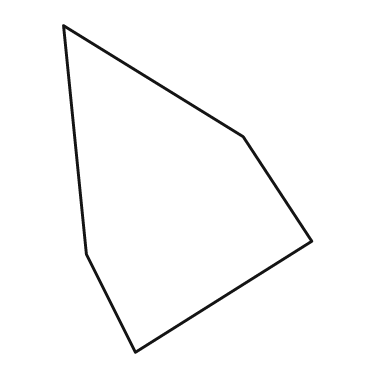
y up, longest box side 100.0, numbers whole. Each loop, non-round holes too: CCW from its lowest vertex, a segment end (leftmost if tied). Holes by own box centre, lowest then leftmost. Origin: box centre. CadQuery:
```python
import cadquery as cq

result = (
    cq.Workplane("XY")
    .moveTo(-16.0, -50.0)
    .lineTo(38.0, -16.0)
    .lineTo(17.0, 16.0)
    .lineTo(-38.0, 50.0)
    .lineTo(-31.0, -20.0)
    .close()
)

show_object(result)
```